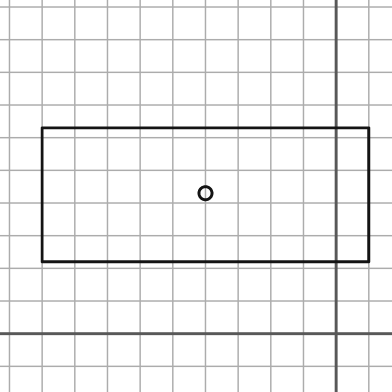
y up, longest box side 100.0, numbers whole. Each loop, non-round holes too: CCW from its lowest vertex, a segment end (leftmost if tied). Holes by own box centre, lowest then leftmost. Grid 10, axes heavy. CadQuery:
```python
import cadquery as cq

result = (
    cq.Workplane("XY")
    .moveTo(-90.0, 22.0)
    .lineTo(10.0, 22.0)
    .lineTo(10.0, 63.0)
    .lineTo(-90.0, 63.0)
    .close()
    .moveTo(-40.0, 43.0)
    .circle(2.0)
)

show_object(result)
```